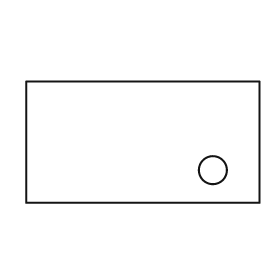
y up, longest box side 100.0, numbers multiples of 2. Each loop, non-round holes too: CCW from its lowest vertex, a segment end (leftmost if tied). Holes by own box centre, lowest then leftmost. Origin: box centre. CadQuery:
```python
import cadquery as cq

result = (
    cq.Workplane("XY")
    .moveTo(-50.0, -26.0)
    .lineTo(50.0, -26.0)
    .lineTo(50.0, 26.0)
    .lineTo(-50.0, 26.0)
    .close()
    .moveTo(30.0, -12.0)
    .circle(6.0)
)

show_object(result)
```